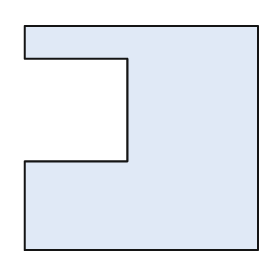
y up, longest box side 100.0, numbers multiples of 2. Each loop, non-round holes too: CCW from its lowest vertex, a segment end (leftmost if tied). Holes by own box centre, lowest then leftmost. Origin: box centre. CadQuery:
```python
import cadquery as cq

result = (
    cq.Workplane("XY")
    .moveTo(-50.0, -48.0)
    .lineTo(50.0, -48.0)
    .lineTo(50.0, 48.0)
    .lineTo(-50.0, 48.0)
    .lineTo(-50.0, 34.0)
    .lineTo(-6.0, 34.0)
    .lineTo(-6.0, -10.0)
    .lineTo(-50.0, -10.0)
    .close()
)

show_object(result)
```